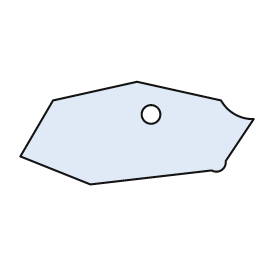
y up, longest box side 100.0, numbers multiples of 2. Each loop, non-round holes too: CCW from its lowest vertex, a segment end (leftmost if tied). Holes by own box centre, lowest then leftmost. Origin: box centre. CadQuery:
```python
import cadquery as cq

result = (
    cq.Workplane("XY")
    .moveTo(-20.0, -22.0)
    .lineTo(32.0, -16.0)
    .threePointArc((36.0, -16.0), (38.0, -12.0))
    .lineTo(50.0, 6.0)
    .threePointArc((42.0, 8.0), (36.0, 14.0))
    .lineTo(0.0, 22.0)
    .lineTo(-36.0, 14.0)
    .lineTo(-50.0, -10.0)
    .close()
    .moveTo(6.0, 8.0)
    .circle(4.0)
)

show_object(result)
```